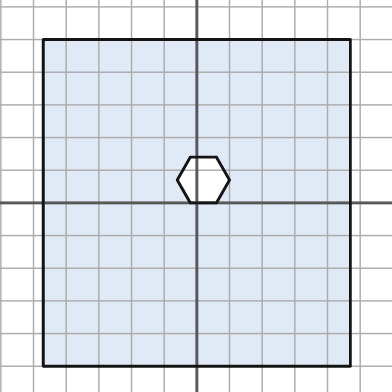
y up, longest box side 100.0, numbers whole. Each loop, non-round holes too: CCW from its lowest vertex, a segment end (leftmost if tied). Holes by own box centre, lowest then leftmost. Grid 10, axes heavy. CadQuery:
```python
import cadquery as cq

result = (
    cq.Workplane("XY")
    .moveTo(-47.0, -50.0)
    .lineTo(47.0, -50.0)
    .lineTo(47.0, 50.0)
    .lineTo(-47.0, 50.0)
    .close()
    .moveTo(-2.0, 0.0)
    .lineTo(6.0, 0.0)
    .lineTo(10.0, 7.0)
    .lineTo(6.0, 14.0)
    .lineTo(-2.0, 14.0)
    .lineTo(-6.0, 7.0)
    .close()
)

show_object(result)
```